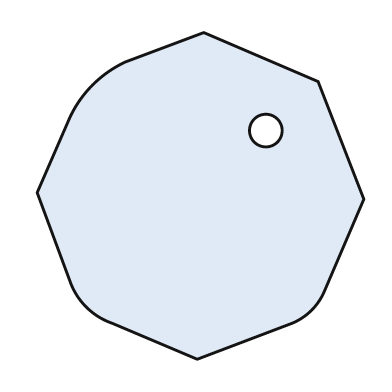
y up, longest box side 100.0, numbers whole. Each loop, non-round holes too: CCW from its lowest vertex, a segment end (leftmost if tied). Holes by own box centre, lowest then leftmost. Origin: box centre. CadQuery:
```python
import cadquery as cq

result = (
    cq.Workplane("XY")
    .moveTo(-1.0, -50.0)
    .lineTo(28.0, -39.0)
    .threePointArc((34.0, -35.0), (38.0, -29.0))
    .lineTo(50.0, -1.0)
    .lineTo(36.0, 35.0)
    .lineTo(1.0, 50.0)
    .lineTo(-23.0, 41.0)
    .threePointArc((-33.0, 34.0), (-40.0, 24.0))
    .lineTo(-50.0, 1.0)
    .lineTo(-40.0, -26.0)
    .threePointArc((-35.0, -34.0), (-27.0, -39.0))
    .close()
    .moveTo(20.0, 20.0)
    .circle(5.0)
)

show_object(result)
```